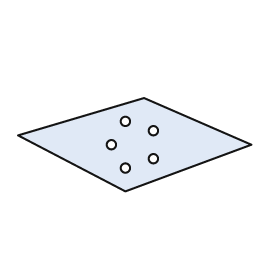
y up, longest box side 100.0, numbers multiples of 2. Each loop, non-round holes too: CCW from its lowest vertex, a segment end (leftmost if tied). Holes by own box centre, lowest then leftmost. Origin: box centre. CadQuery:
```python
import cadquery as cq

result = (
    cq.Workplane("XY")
    .moveTo(-4.0, -20.0)
    .lineTo(50.0, 0.0)
    .lineTo(4.0, 20.0)
    .lineTo(-50.0, 4.0)
    .close()
    .moveTo(-4.0, -10.0)
    .circle(2.0)
    .moveTo(8.0, -6.0)
    .circle(2.0)
    .moveTo(-10.0, 0.0)
    .circle(2.0)
    .moveTo(8.0, 6.0)
    .circle(2.0)
    .moveTo(-4.0, 10.0)
    .circle(2.0)
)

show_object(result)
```